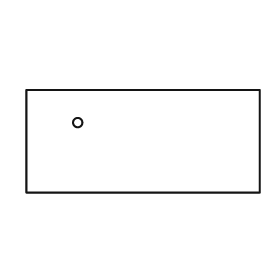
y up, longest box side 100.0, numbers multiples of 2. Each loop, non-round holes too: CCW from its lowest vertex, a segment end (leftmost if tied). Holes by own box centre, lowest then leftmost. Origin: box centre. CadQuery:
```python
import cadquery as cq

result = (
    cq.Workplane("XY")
    .moveTo(-50.0, -22.0)
    .lineTo(50.0, -22.0)
    .lineTo(50.0, 22.0)
    .lineTo(-50.0, 22.0)
    .close()
    .moveTo(-28.0, 8.0)
    .circle(2.0)
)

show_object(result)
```